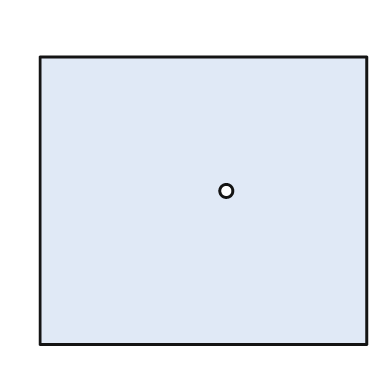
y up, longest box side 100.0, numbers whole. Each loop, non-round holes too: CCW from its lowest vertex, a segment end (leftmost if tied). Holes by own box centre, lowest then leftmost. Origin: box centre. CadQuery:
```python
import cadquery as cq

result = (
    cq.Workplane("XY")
    .moveTo(-50.0, -44.0)
    .lineTo(50.0, -44.0)
    .lineTo(50.0, 44.0)
    .lineTo(-50.0, 44.0)
    .close()
    .moveTo(7.0, 3.0)
    .circle(2.0)
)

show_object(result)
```